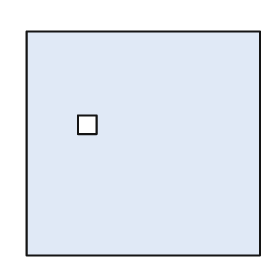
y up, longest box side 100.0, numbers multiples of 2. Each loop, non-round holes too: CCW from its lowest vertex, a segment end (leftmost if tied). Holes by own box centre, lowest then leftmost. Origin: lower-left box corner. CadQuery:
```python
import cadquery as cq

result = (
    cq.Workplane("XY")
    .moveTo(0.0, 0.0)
    .lineTo(100.0, 0.0)
    .lineTo(100.0, 96.0)
    .lineTo(0.0, 96.0)
    .close()
    .moveTo(22.0, 52.0)
    .lineTo(30.0, 52.0)
    .lineTo(30.0, 60.0)
    .lineTo(22.0, 60.0)
    .close()
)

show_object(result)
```